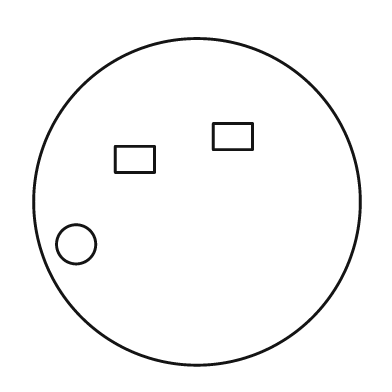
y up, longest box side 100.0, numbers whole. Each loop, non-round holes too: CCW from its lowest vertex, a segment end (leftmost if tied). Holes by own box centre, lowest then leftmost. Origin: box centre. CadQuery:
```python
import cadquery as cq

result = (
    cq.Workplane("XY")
    .moveTo(0.0, 0.0)
    .circle(50.0)
    .moveTo(-37.0, -13.0)
    .circle(6.0)
    .moveTo(-25.0, 9.0)
    .lineTo(-13.0, 9.0)
    .lineTo(-13.0, 17.0)
    .lineTo(-25.0, 17.0)
    .close()
    .moveTo(5.0, 16.0)
    .lineTo(17.0, 16.0)
    .lineTo(17.0, 24.0)
    .lineTo(5.0, 24.0)
    .close()
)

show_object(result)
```